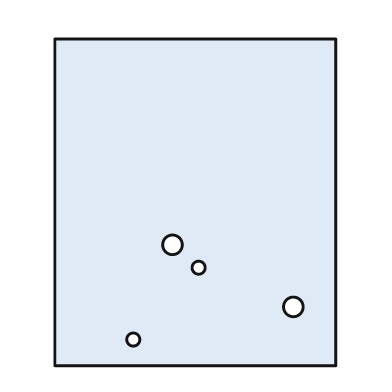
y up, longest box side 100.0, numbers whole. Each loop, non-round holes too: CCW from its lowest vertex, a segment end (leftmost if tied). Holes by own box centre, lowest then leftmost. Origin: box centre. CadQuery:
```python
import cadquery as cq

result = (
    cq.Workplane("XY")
    .moveTo(-43.0, -50.0)
    .lineTo(43.0, -50.0)
    .lineTo(43.0, 50.0)
    .lineTo(-43.0, 50.0)
    .close()
    .moveTo(-19.0, -42.0)
    .circle(2.0)
    .moveTo(30.0, -32.0)
    .circle(3.0)
    .moveTo(1.0, -20.0)
    .circle(2.0)
    .moveTo(-7.0, -13.0)
    .circle(3.0)
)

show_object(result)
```